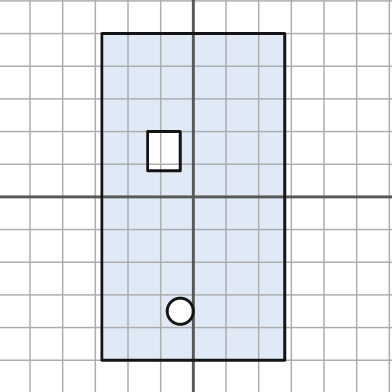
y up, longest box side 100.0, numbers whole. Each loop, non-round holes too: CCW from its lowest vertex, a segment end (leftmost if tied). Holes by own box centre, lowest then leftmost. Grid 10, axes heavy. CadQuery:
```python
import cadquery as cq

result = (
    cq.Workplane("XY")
    .moveTo(-28.0, -50.0)
    .lineTo(28.0, -50.0)
    .lineTo(28.0, 50.0)
    .lineTo(-28.0, 50.0)
    .close()
    .moveTo(-4.0, -35.0)
    .circle(4.0)
    .moveTo(-14.0, 8.0)
    .lineTo(-4.0, 8.0)
    .lineTo(-4.0, 20.0)
    .lineTo(-14.0, 20.0)
    .close()
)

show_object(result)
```